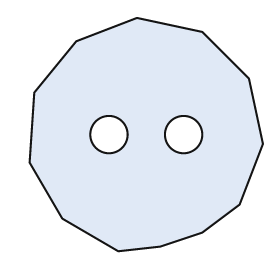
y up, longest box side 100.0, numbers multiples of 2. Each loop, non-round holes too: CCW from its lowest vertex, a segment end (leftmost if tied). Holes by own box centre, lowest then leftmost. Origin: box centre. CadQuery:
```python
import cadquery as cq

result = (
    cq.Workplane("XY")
    .moveTo(-12.0, -50.0)
    .lineTo(6.0, -48.0)
    .lineTo(24.0, -42.0)
    .lineTo(40.0, -30.0)
    .lineTo(50.0, -4.0)
    .lineTo(44.0, 24.0)
    .lineTo(24.0, 44.0)
    .lineTo(-4.0, 50.0)
    .lineTo(-30.0, 40.0)
    .lineTo(-48.0, 18.0)
    .lineTo(-50.0, -12.0)
    .lineTo(-36.0, -36.0)
    .close()
    .moveTo(-16.0, 0.0)
    .circle(8.0)
    .moveTo(16.0, 0.0)
    .circle(8.0)
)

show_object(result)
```